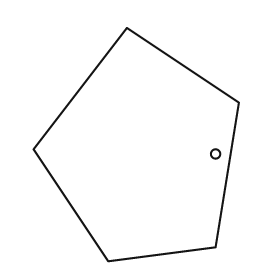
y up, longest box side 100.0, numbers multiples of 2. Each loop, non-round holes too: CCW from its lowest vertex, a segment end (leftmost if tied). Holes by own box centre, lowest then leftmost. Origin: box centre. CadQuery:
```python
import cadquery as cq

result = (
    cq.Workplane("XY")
    .moveTo(-12.0, -50.0)
    .lineTo(34.0, -44.0)
    .lineTo(44.0, 18.0)
    .lineTo(-4.0, 50.0)
    .lineTo(-44.0, -2.0)
    .close()
    .moveTo(34.0, -4.0)
    .circle(2.0)
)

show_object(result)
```